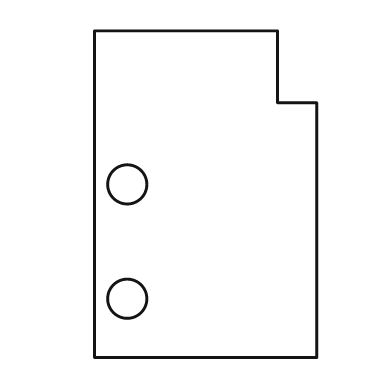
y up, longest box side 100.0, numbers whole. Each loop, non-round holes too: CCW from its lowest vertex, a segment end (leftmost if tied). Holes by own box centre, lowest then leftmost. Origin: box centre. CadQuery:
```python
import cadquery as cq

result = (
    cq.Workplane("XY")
    .moveTo(-34.0, -50.0)
    .lineTo(34.0, -50.0)
    .lineTo(34.0, 28.0)
    .lineTo(22.0, 28.0)
    .lineTo(22.0, 50.0)
    .lineTo(-34.0, 50.0)
    .close()
    .moveTo(-24.0, -32.0)
    .circle(6.0)
    .moveTo(-24.0, 3.0)
    .circle(6.0)
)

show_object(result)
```